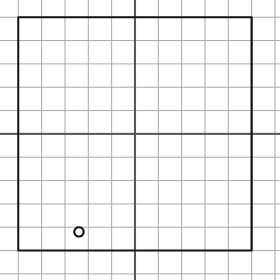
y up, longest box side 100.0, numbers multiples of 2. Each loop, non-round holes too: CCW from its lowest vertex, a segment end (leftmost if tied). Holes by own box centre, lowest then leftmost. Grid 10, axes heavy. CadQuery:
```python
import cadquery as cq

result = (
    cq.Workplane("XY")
    .moveTo(-50.0, -50.0)
    .lineTo(50.0, -50.0)
    .lineTo(50.0, 50.0)
    .lineTo(-50.0, 50.0)
    .close()
    .moveTo(-24.0, -42.0)
    .circle(2.0)
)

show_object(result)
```